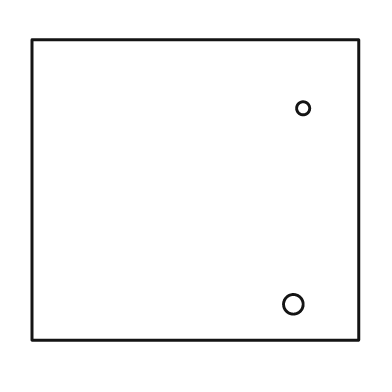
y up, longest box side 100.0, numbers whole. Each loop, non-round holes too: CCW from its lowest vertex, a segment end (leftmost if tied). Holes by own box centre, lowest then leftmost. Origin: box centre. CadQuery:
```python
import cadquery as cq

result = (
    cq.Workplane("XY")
    .moveTo(-50.0, -46.0)
    .lineTo(50.0, -46.0)
    .lineTo(50.0, 46.0)
    .lineTo(-50.0, 46.0)
    .close()
    .moveTo(30.0, -35.0)
    .circle(3.0)
    .moveTo(33.0, 25.0)
    .circle(2.0)
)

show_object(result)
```